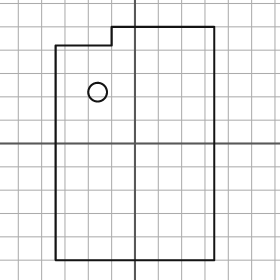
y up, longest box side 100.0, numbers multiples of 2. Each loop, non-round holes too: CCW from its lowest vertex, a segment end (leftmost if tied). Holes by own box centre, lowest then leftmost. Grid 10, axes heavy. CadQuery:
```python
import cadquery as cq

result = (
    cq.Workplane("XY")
    .moveTo(-34.0, -50.0)
    .lineTo(34.0, -50.0)
    .lineTo(34.0, 50.0)
    .lineTo(-10.0, 50.0)
    .lineTo(-10.0, 42.0)
    .lineTo(-34.0, 42.0)
    .close()
    .moveTo(-16.0, 22.0)
    .circle(4.0)
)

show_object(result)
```